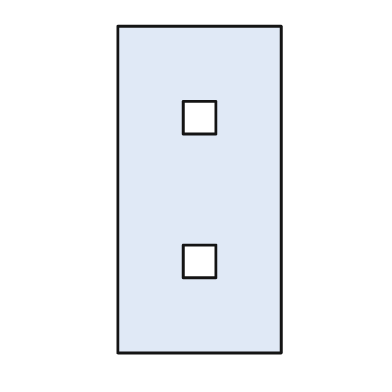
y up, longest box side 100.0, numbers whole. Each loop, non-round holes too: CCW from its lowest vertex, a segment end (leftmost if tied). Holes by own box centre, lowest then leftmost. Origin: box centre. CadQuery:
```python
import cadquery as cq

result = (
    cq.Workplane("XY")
    .moveTo(-25.0, -50.0)
    .lineTo(25.0, -50.0)
    .lineTo(25.0, 50.0)
    .lineTo(-25.0, 50.0)
    .close()
    .moveTo(-5.0, -27.0)
    .lineTo(5.0, -27.0)
    .lineTo(5.0, -17.0)
    .lineTo(-5.0, -17.0)
    .close()
    .moveTo(-5.0, 17.0)
    .lineTo(5.0, 17.0)
    .lineTo(5.0, 27.0)
    .lineTo(-5.0, 27.0)
    .close()
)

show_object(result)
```